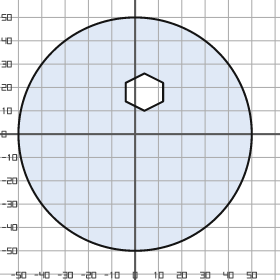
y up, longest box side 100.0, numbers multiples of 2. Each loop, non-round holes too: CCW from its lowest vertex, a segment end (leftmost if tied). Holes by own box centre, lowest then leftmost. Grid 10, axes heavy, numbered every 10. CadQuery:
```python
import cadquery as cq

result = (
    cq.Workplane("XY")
    .moveTo(0.0, 0.0)
    .circle(50.0)
    .moveTo(4.0, 10.0)
    .lineTo(12.0, 14.0)
    .lineTo(12.0, 22.0)
    .lineTo(4.0, 26.0)
    .lineTo(-4.0, 22.0)
    .lineTo(-4.0, 14.0)
    .close()
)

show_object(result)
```